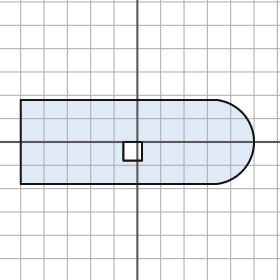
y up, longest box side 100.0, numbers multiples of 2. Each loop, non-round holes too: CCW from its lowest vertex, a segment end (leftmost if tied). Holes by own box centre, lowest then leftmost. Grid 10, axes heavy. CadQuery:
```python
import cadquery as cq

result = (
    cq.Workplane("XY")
    .moveTo(-50.0, -18.0)
    .lineTo(34.0, -18.0)
    .threePointArc((50.0, 0.0), (34.0, 18.0))
    .lineTo(-50.0, 18.0)
    .close()
    .moveTo(-6.0, -8.0)
    .lineTo(2.0, -8.0)
    .lineTo(2.0, 0.0)
    .lineTo(-6.0, 0.0)
    .close()
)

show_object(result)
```